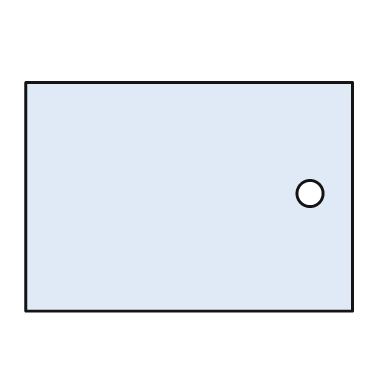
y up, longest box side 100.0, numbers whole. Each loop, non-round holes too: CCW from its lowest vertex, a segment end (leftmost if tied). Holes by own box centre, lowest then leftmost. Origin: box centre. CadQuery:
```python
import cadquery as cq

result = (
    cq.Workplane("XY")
    .moveTo(-50.0, -35.0)
    .lineTo(50.0, -35.0)
    .lineTo(50.0, 35.0)
    .lineTo(-50.0, 35.0)
    .close()
    .moveTo(37.0, 1.0)
    .circle(4.0)
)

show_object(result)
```